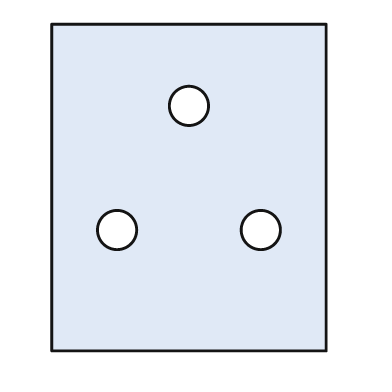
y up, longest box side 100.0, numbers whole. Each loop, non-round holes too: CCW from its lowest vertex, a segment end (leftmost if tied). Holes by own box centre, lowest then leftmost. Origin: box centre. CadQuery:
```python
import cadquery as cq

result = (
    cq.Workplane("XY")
    .moveTo(-42.0, -50.0)
    .lineTo(42.0, -50.0)
    .lineTo(42.0, 50.0)
    .lineTo(-42.0, 50.0)
    .close()
    .moveTo(-22.0, -13.0)
    .circle(6.0)
    .moveTo(22.0, -13.0)
    .circle(6.0)
    .moveTo(0.0, 25.0)
    .circle(6.0)
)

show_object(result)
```